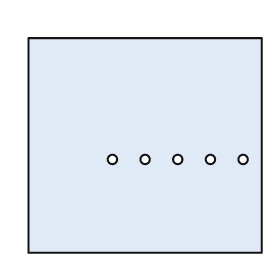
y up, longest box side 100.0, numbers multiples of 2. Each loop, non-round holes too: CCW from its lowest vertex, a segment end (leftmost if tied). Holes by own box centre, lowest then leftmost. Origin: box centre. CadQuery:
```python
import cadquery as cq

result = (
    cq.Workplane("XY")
    .moveTo(-50.0, -46.0)
    .lineTo(50.0, -46.0)
    .lineTo(50.0, 46.0)
    .lineTo(-50.0, 46.0)
    .close()
    .moveTo(-14.0, -6.0)
    .circle(2.0)
    .moveTo(0.0, -6.0)
    .circle(2.0)
    .moveTo(14.0, -6.0)
    .circle(2.0)
    .moveTo(28.0, -6.0)
    .circle(2.0)
    .moveTo(42.0, -6.0)
    .circle(2.0)
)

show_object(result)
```